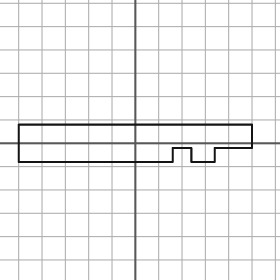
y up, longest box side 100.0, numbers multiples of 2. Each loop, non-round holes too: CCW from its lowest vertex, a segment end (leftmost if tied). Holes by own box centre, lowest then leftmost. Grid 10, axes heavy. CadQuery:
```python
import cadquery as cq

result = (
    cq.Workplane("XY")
    .moveTo(-50.0, -8.0)
    .lineTo(16.0, -8.0)
    .lineTo(16.0, -2.0)
    .lineTo(24.0, -2.0)
    .lineTo(24.0, -8.0)
    .lineTo(34.0, -8.0)
    .lineTo(34.0, -2.0)
    .lineTo(50.0, -2.0)
    .lineTo(50.0, 8.0)
    .lineTo(-50.0, 8.0)
    .close()
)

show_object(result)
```